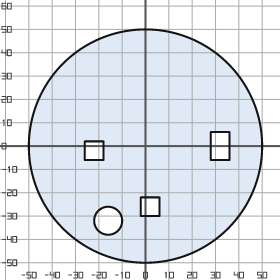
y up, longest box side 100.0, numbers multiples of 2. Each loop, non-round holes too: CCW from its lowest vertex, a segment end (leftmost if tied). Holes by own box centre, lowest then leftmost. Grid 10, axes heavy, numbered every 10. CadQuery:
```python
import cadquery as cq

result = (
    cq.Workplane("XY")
    .moveTo(0.0, 0.0)
    .circle(50.0)
    .moveTo(-16.0, -32.0)
    .circle(6.0)
    .moveTo(-2.0, -30.0)
    .lineTo(6.0, -30.0)
    .lineTo(6.0, -22.0)
    .lineTo(-2.0, -22.0)
    .close()
    .moveTo(-26.0, -6.0)
    .lineTo(-18.0, -6.0)
    .lineTo(-18.0, 2.0)
    .lineTo(-26.0, 2.0)
    .close()
    .moveTo(28.0, -6.0)
    .lineTo(36.0, -6.0)
    .lineTo(36.0, 6.0)
    .lineTo(28.0, 6.0)
    .close()
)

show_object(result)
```